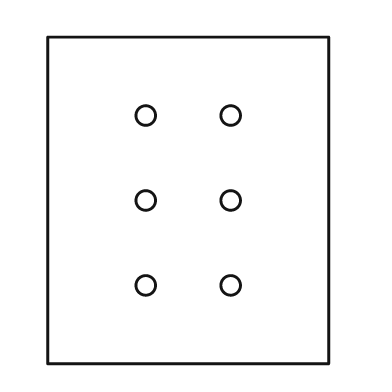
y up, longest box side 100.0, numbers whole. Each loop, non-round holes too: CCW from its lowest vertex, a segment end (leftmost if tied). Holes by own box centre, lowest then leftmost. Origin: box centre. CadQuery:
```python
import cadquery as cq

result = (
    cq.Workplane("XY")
    .moveTo(-43.0, -50.0)
    .lineTo(43.0, -50.0)
    .lineTo(43.0, 50.0)
    .lineTo(-43.0, 50.0)
    .close()
    .moveTo(-13.0, -26.0)
    .circle(3.0)
    .moveTo(13.0, -26.0)
    .circle(3.0)
    .moveTo(-13.0, 0.0)
    .circle(3.0)
    .moveTo(13.0, 0.0)
    .circle(3.0)
    .moveTo(-13.0, 26.0)
    .circle(3.0)
    .moveTo(13.0, 26.0)
    .circle(3.0)
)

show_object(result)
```